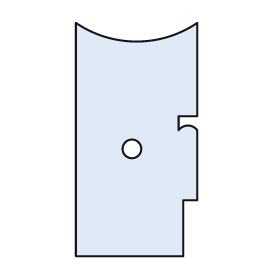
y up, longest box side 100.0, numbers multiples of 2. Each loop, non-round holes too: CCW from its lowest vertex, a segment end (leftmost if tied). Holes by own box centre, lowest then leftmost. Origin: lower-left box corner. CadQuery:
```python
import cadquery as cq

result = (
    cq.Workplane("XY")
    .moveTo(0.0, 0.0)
    .lineTo(46.0, 0.0)
    .lineTo(46.0, 24.0)
    .lineTo(52.0, 24.0)
    .lineTo(52.0, 54.0)
    .threePointArc((48.0, 56.0), (44.0, 54.0))
    .lineTo(44.0, 60.0)
    .lineTo(52.0, 60.0)
    .lineTo(52.0, 100.0)
    .threePointArc((26.0, 92.0), (0.0, 100.0))
    .close()
    .moveTo(24.0, 46.0)
    .circle(4.0)
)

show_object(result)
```